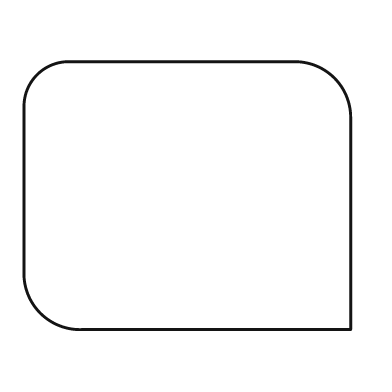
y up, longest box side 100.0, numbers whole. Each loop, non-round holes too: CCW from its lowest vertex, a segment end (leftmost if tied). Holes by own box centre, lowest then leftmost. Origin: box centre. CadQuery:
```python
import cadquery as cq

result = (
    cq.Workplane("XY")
    .moveTo(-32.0, -41.0)
    .lineTo(50.0, -41.0)
    .lineTo(50.0, 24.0)
    .threePointArc((45.0, 36.0), (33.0, 41.0))
    .lineTo(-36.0, 41.0)
    .threePointArc((-46.0, 37.0), (-50.0, 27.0))
    .lineTo(-50.0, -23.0)
    .threePointArc((-45.0, -36.0), (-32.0, -41.0))
    .close()
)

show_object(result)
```